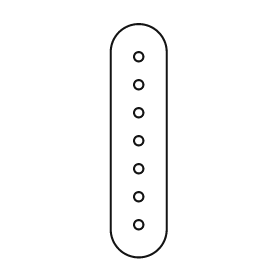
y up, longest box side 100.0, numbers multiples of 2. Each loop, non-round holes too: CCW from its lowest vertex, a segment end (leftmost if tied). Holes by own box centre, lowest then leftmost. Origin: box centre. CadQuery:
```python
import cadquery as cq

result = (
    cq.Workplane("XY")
    .moveTo(-12.0, -38.0)
    .threePointArc((0.0, -50.0), (12.0, -38.0))
    .lineTo(12.0, 38.0)
    .threePointArc((0.0, 50.0), (-12.0, 38.0))
    .close()
    .moveTo(0.0, -36.0)
    .circle(2.0)
    .moveTo(0.0, -24.0)
    .circle(2.0)
    .moveTo(0.0, -12.0)
    .circle(2.0)
    .moveTo(0.0, 0.0)
    .circle(2.0)
    .moveTo(0.0, 12.0)
    .circle(2.0)
    .moveTo(0.0, 24.0)
    .circle(2.0)
    .moveTo(0.0, 36.0)
    .circle(2.0)
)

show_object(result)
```